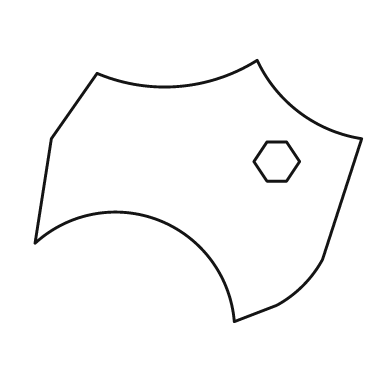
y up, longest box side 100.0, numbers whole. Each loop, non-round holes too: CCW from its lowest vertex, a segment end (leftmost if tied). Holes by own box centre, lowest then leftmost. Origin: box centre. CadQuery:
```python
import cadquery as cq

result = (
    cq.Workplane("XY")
    .moveTo(11.0, -40.0)
    .lineTo(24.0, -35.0)
    .threePointArc((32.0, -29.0), (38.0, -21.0))
    .lineTo(50.0, 16.0)
    .threePointArc((31.0, 24.0), (18.0, 40.0))
    .threePointArc((-6.0, 32.0), (-31.0, 36.0))
    .lineTo(-45.0, 16.0)
    .lineTo(-50.0, -16.0)
    .threePointArc((-12.0, -9.0), (11.0, -40.0))
    .close()
    .moveTo(21.0, 3.0)
    .lineTo(27.0, 3.0)
    .lineTo(31.0, 9.0)
    .lineTo(27.0, 15.0)
    .lineTo(21.0, 15.0)
    .lineTo(17.0, 9.0)
    .close()
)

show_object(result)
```